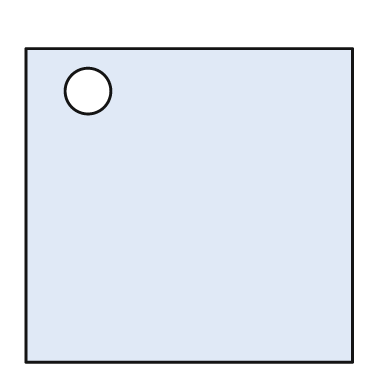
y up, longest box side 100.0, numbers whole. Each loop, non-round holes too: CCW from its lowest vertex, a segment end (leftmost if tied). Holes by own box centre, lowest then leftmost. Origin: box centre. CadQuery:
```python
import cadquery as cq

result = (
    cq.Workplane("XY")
    .moveTo(-50.0, -48.0)
    .lineTo(50.0, -48.0)
    .lineTo(50.0, 48.0)
    .lineTo(-50.0, 48.0)
    .close()
    .moveTo(-31.0, 35.0)
    .circle(7.0)
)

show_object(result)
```